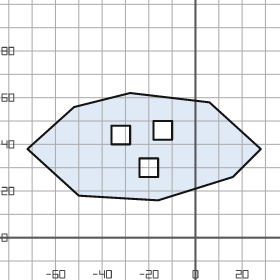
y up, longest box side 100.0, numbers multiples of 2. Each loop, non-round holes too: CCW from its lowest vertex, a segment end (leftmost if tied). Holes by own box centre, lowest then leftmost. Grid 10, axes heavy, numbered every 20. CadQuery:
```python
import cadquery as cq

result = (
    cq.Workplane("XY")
    .moveTo(-16.0, 16.0)
    .lineTo(16.0, 26.0)
    .lineTo(28.0, 38.0)
    .lineTo(6.0, 58.0)
    .lineTo(-28.0, 62.0)
    .lineTo(-52.0, 56.0)
    .lineTo(-72.0, 38.0)
    .lineTo(-50.0, 18.0)
    .close()
    .moveTo(-24.0, 26.0)
    .lineTo(-16.0, 26.0)
    .lineTo(-16.0, 34.0)
    .lineTo(-24.0, 34.0)
    .close()
    .moveTo(-36.0, 40.0)
    .lineTo(-28.0, 40.0)
    .lineTo(-28.0, 48.0)
    .lineTo(-36.0, 48.0)
    .close()
    .moveTo(-18.0, 42.0)
    .lineTo(-10.0, 42.0)
    .lineTo(-10.0, 50.0)
    .lineTo(-18.0, 50.0)
    .close()
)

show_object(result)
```